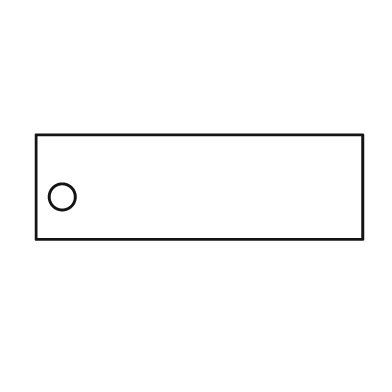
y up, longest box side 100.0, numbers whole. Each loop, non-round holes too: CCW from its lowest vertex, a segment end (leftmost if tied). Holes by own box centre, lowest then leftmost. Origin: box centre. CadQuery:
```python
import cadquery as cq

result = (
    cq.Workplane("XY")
    .moveTo(-50.0, -16.0)
    .lineTo(50.0, -16.0)
    .lineTo(50.0, 16.0)
    .lineTo(-50.0, 16.0)
    .close()
    .moveTo(-42.0, -3.0)
    .circle(4.0)
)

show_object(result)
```